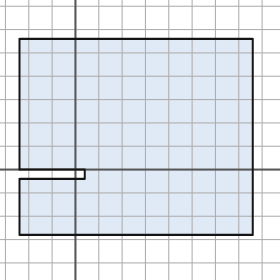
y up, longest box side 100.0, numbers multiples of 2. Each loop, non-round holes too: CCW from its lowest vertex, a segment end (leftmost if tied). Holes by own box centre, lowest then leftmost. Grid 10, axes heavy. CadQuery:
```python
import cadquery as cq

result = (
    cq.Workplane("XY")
    .moveTo(-24.0, -28.0)
    .lineTo(76.0, -28.0)
    .lineTo(76.0, 56.0)
    .lineTo(-24.0, 56.0)
    .lineTo(-24.0, 0.0)
    .lineTo(4.0, 0.0)
    .lineTo(4.0, -4.0)
    .lineTo(-24.0, -4.0)
    .close()
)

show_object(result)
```